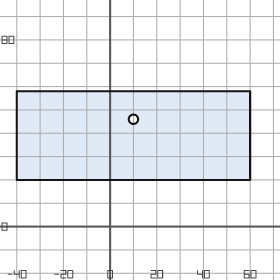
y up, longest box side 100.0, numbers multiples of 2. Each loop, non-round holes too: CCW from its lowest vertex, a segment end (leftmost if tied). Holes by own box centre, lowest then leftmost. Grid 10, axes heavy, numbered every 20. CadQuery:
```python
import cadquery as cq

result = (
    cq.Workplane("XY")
    .moveTo(-40.0, 20.0)
    .lineTo(60.0, 20.0)
    .lineTo(60.0, 58.0)
    .lineTo(-40.0, 58.0)
    .close()
    .moveTo(10.0, 46.0)
    .circle(2.0)
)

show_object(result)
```